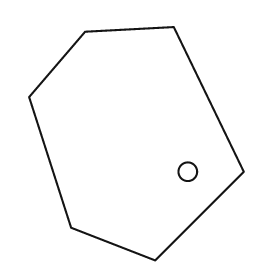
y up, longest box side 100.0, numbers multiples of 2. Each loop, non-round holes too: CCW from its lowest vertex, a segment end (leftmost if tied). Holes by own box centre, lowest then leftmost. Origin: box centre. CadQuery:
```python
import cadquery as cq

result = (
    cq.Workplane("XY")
    .moveTo(8.0, -50.0)
    .lineTo(46.0, -12.0)
    .lineTo(16.0, 50.0)
    .lineTo(-22.0, 48.0)
    .lineTo(-46.0, 20.0)
    .lineTo(-28.0, -36.0)
    .close()
    .moveTo(22.0, -12.0)
    .circle(4.0)
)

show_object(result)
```